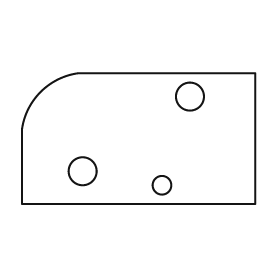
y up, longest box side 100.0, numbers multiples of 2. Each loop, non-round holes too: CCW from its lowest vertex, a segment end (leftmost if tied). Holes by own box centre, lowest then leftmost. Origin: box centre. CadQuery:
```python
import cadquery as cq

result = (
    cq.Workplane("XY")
    .moveTo(-50.0, -28.0)
    .lineTo(50.0, -28.0)
    .lineTo(50.0, 28.0)
    .lineTo(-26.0, 28.0)
    .threePointArc((-42.0, 20.0), (-50.0, 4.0))
    .close()
    .moveTo(10.0, -20.0)
    .circle(4.0)
    .moveTo(-24.0, -14.0)
    .circle(6.0)
    .moveTo(22.0, 18.0)
    .circle(6.0)
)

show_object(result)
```